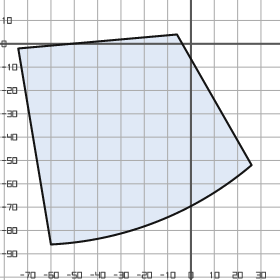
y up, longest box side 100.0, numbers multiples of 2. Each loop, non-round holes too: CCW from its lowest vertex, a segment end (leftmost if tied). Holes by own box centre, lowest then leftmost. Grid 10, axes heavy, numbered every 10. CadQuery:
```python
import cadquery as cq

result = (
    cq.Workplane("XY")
    .moveTo(-60.0, -86.0)
    .threePointArc((-14.0, -76.0), (26.0, -52.0))
    .lineTo(-6.0, 4.0)
    .lineTo(-74.0, -2.0)
    .close()
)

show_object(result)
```